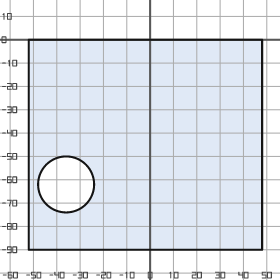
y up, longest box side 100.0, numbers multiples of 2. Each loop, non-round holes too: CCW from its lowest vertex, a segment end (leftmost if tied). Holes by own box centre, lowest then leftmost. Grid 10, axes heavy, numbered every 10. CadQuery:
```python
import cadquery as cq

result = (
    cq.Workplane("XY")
    .moveTo(-52.0, -90.0)
    .lineTo(48.0, -90.0)
    .lineTo(48.0, 0.0)
    .lineTo(-52.0, 0.0)
    .close()
    .moveTo(-36.0, -62.0)
    .circle(12.0)
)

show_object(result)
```